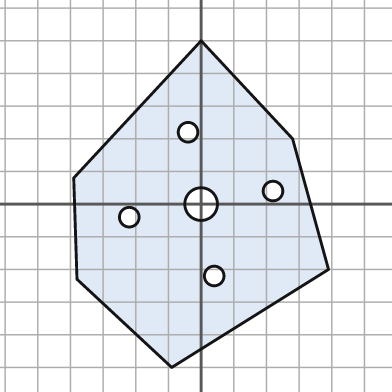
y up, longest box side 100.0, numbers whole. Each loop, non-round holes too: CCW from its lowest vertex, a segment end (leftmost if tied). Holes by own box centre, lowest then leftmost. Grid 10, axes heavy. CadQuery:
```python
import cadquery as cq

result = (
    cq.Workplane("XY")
    .moveTo(-9.0, -50.0)
    .lineTo(39.0, -20.0)
    .lineTo(28.0, 20.0)
    .lineTo(0.0, 50.0)
    .lineTo(-39.0, 8.0)
    .lineTo(-38.0, -23.0)
    .close()
    .moveTo(4.0, -22.0)
    .circle(3.0)
    .moveTo(-22.0, -4.0)
    .circle(3.0)
    .moveTo(0.0, 0.0)
    .circle(5.0)
    .moveTo(22.0, 4.0)
    .circle(3.0)
    .moveTo(-4.0, 22.0)
    .circle(3.0)
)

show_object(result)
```